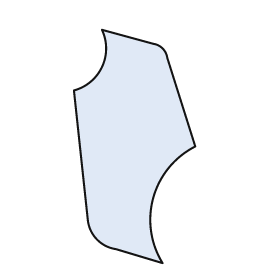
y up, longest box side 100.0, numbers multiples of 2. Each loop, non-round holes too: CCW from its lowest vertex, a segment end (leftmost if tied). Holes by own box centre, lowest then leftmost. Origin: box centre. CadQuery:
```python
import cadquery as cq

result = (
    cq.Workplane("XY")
    .moveTo(12.0, -50.0)
    .threePointArc((8.0, -22.0), (26.0, 0.0))
    .lineTo(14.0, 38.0)
    .threePointArc((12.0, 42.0), (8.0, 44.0))
    .lineTo(-14.0, 50.0)
    .threePointArc((-14.0, 34.0), (-26.0, 24.0))
    .lineTo(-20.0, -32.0)
    .threePointArc((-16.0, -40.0), (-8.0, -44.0))
    .close()
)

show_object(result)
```